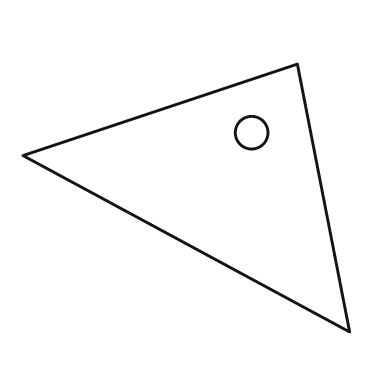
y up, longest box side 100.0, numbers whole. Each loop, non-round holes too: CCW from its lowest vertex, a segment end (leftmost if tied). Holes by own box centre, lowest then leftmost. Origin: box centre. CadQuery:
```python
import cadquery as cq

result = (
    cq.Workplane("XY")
    .moveTo(50.0, -41.0)
    .lineTo(34.0, 41.0)
    .lineTo(-50.0, 13.0)
    .close()
    .moveTo(20.0, 20.0)
    .circle(5.0)
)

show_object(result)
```